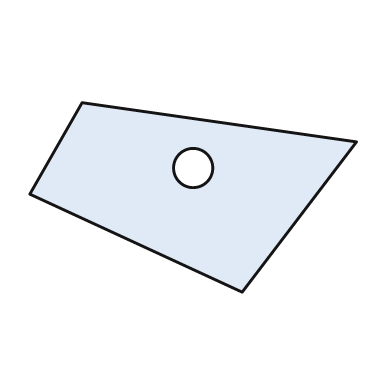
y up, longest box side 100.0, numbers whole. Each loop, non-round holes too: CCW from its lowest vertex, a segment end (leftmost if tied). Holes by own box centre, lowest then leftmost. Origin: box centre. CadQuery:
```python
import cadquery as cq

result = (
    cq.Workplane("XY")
    .moveTo(15.0, -29.0)
    .lineTo(50.0, 17.0)
    .lineTo(-34.0, 29.0)
    .lineTo(-50.0, 1.0)
    .close()
    .moveTo(0.0, 9.0)
    .circle(6.0)
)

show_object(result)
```